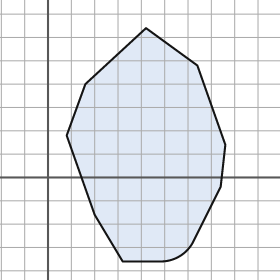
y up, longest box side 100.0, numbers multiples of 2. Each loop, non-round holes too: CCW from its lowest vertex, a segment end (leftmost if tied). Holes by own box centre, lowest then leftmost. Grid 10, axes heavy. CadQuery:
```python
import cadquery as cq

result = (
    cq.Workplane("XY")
    .moveTo(32.0, -36.0)
    .lineTo(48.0, -36.0)
    .threePointArc((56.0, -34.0), (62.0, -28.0))
    .lineTo(74.0, -4.0)
    .lineTo(76.0, 14.0)
    .lineTo(64.0, 48.0)
    .lineTo(42.0, 64.0)
    .lineTo(16.0, 40.0)
    .lineTo(8.0, 18.0)
    .lineTo(20.0, -16.0)
    .close()
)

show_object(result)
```